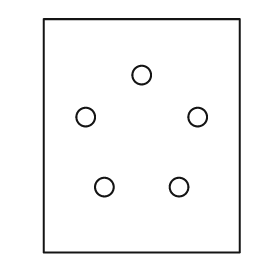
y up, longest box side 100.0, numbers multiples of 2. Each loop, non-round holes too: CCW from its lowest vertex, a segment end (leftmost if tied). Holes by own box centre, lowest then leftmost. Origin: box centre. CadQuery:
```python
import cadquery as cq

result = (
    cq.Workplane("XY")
    .moveTo(-42.0, -50.0)
    .lineTo(42.0, -50.0)
    .lineTo(42.0, 50.0)
    .lineTo(-42.0, 50.0)
    .close()
    .moveTo(-16.0, -22.0)
    .circle(4.0)
    .moveTo(16.0, -22.0)
    .circle(4.0)
    .moveTo(-24.0, 8.0)
    .circle(4.0)
    .moveTo(24.0, 8.0)
    .circle(4.0)
    .moveTo(0.0, 26.0)
    .circle(4.0)
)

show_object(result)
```